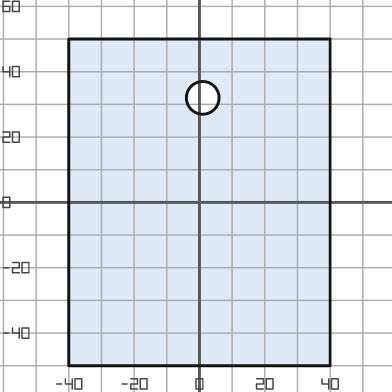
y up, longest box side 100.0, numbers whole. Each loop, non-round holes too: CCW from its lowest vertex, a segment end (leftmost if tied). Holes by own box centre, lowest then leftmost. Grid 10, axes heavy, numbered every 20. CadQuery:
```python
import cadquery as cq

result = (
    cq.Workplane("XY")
    .moveTo(-40.0, -50.0)
    .lineTo(40.0, -50.0)
    .lineTo(40.0, 50.0)
    .lineTo(-40.0, 50.0)
    .close()
    .moveTo(1.0, 32.0)
    .circle(5.0)
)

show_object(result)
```